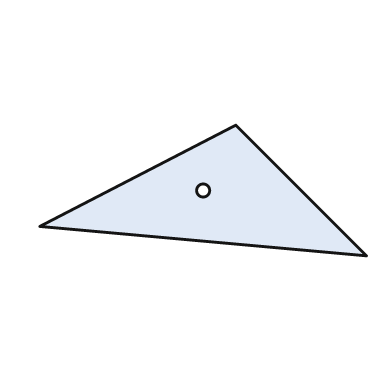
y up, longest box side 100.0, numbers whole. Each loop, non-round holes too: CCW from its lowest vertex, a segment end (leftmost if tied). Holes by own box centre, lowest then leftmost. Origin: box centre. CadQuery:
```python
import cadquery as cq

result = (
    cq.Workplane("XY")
    .moveTo(50.0, -20.0)
    .lineTo(10.0, 20.0)
    .lineTo(-50.0, -11.0)
    .close()
    .moveTo(0.0, 0.0)
    .circle(2.0)
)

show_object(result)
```